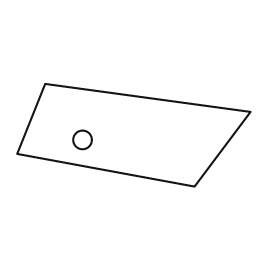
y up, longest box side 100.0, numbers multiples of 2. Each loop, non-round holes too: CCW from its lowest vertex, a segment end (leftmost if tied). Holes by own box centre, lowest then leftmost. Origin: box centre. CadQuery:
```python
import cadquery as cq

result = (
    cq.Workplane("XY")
    .moveTo(26.0, -22.0)
    .lineTo(50.0, 10.0)
    .lineTo(-38.0, 22.0)
    .lineTo(-50.0, -8.0)
    .close()
    .moveTo(-22.0, -2.0)
    .circle(4.0)
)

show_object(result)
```